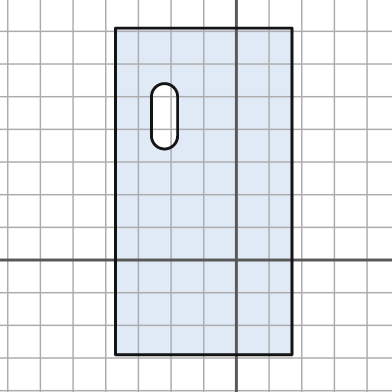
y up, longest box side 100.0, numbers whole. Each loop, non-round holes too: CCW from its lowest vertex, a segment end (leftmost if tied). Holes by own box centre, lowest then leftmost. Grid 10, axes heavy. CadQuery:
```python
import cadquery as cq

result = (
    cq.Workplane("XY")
    .moveTo(-37.0, -29.0)
    .lineTo(17.0, -29.0)
    .lineTo(17.0, 71.0)
    .lineTo(-37.0, 71.0)
    .close()
    .moveTo(-26.0, 38.0)
    .threePointArc((-22.0, 34.0), (-18.0, 38.0))
    .lineTo(-18.0, 50.0)
    .threePointArc((-22.0, 54.0), (-26.0, 50.0))
    .close()
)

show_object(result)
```